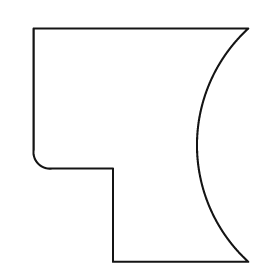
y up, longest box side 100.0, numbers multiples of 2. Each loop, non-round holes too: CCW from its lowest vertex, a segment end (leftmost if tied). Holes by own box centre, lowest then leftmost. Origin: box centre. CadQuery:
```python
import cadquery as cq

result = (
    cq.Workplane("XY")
    .moveTo(-12.0, -50.0)
    .lineTo(46.0, -50.0)
    .threePointArc((24.0, 0.0), (46.0, 50.0))
    .lineTo(-46.0, 50.0)
    .lineTo(-46.0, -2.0)
    .threePointArc((-44.0, -8.0), (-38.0, -10.0))
    .lineTo(-12.0, -10.0)
    .close()
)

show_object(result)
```